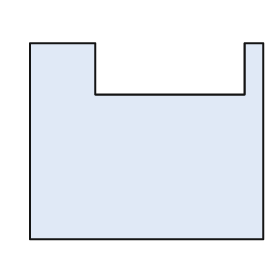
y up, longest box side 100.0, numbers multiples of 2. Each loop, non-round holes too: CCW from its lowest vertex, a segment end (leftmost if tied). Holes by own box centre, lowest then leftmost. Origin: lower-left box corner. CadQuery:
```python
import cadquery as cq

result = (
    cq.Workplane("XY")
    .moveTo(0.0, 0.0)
    .lineTo(100.0, 0.0)
    .lineTo(100.0, 84.0)
    .lineTo(92.0, 84.0)
    .lineTo(92.0, 62.0)
    .lineTo(28.0, 62.0)
    .lineTo(28.0, 84.0)
    .lineTo(0.0, 84.0)
    .close()
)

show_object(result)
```